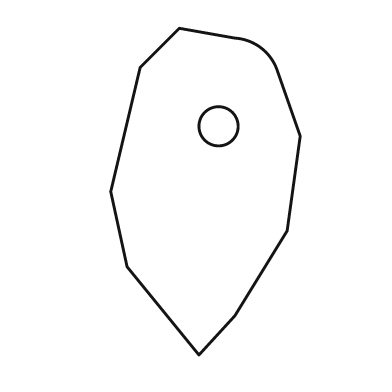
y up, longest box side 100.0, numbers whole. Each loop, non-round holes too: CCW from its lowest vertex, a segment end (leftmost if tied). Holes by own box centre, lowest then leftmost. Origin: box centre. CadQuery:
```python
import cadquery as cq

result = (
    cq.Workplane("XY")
    .moveTo(-2.0, -50.0)
    .lineTo(9.0, -38.0)
    .lineTo(25.0, -12.0)
    .lineTo(29.0, 17.0)
    .lineTo(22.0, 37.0)
    .threePointArc((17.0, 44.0), (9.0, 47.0))
    .lineTo(-8.0, 50.0)
    .lineTo(-20.0, 38.0)
    .lineTo(-29.0, 0.0)
    .lineTo(-24.0, -23.0)
    .close()
    .moveTo(4.0, 20.0)
    .circle(6.0)
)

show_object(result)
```